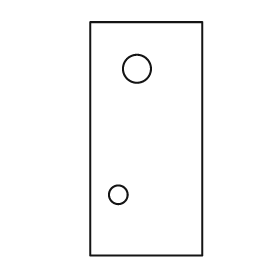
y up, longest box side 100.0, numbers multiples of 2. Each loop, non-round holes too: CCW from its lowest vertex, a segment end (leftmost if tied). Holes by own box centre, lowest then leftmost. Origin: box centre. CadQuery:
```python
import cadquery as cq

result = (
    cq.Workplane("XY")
    .moveTo(-24.0, -50.0)
    .lineTo(24.0, -50.0)
    .lineTo(24.0, 50.0)
    .lineTo(-24.0, 50.0)
    .close()
    .moveTo(-12.0, -24.0)
    .circle(4.0)
    .moveTo(-4.0, 30.0)
    .circle(6.0)
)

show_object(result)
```